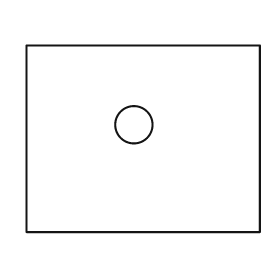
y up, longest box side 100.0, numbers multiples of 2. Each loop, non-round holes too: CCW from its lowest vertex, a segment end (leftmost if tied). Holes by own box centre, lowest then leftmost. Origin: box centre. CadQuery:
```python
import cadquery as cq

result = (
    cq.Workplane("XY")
    .moveTo(-50.0, -40.0)
    .lineTo(50.0, -40.0)
    .lineTo(50.0, 40.0)
    .lineTo(-50.0, 40.0)
    .close()
    .moveTo(-4.0, 6.0)
    .circle(8.0)
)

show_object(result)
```